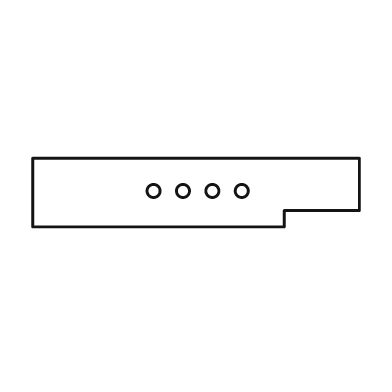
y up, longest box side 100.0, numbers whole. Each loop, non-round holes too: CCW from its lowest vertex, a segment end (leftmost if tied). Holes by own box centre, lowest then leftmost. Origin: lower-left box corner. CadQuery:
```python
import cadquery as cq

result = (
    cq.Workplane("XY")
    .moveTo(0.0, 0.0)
    .lineTo(77.0, 0.0)
    .lineTo(77.0, 5.0)
    .lineTo(100.0, 5.0)
    .lineTo(100.0, 21.0)
    .lineTo(0.0, 21.0)
    .close()
    .moveTo(37.0, 11.0)
    .circle(2.0)
    .moveTo(46.0, 11.0)
    .circle(2.0)
    .moveTo(55.0, 11.0)
    .circle(2.0)
    .moveTo(64.0, 11.0)
    .circle(2.0)
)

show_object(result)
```